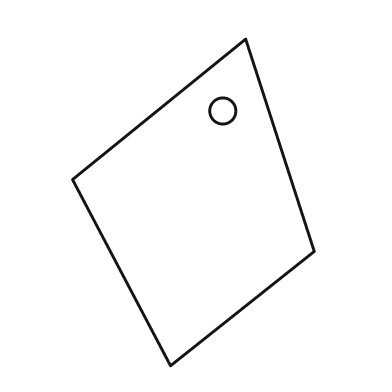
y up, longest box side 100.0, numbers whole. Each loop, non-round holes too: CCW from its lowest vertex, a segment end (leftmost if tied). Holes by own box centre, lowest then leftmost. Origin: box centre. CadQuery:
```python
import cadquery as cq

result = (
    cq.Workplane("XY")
    .moveTo(-7.0, -50.0)
    .lineTo(37.0, -15.0)
    .lineTo(16.0, 50.0)
    .lineTo(-37.0, 7.0)
    .close()
    .moveTo(9.0, 28.0)
    .circle(4.0)
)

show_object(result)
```